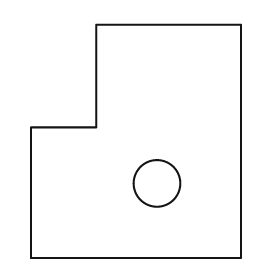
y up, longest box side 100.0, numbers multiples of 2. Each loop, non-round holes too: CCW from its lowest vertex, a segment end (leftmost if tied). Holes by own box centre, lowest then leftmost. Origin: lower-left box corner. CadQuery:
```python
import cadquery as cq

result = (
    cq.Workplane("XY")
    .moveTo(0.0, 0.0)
    .lineTo(90.0, 0.0)
    .lineTo(90.0, 100.0)
    .lineTo(28.0, 100.0)
    .lineTo(28.0, 56.0)
    .lineTo(0.0, 56.0)
    .close()
    .moveTo(54.0, 32.0)
    .circle(10.0)
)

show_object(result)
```